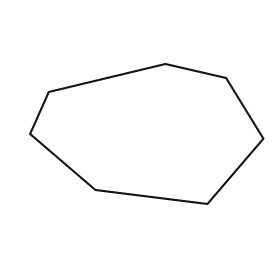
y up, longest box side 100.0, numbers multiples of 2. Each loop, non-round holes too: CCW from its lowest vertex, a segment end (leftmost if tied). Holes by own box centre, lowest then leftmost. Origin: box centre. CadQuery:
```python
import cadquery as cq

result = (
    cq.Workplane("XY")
    .moveTo(26.0, -30.0)
    .lineTo(50.0, -2.0)
    .lineTo(34.0, 24.0)
    .lineTo(8.0, 30.0)
    .lineTo(-42.0, 18.0)
    .lineTo(-50.0, 0.0)
    .lineTo(-22.0, -24.0)
    .close()
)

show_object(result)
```